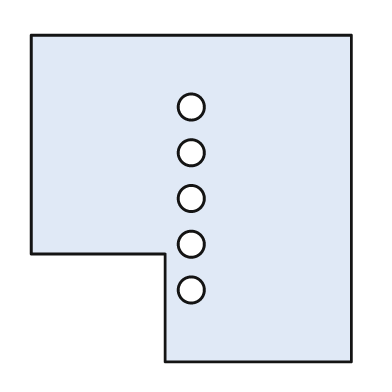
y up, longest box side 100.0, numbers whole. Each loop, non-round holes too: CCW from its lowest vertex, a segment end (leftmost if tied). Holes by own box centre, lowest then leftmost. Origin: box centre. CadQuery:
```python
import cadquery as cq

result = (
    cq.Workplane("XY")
    .moveTo(-8.0, -50.0)
    .lineTo(49.0, -50.0)
    .lineTo(49.0, 50.0)
    .lineTo(-49.0, 50.0)
    .lineTo(-49.0, -17.0)
    .lineTo(-8.0, -17.0)
    .close()
    .moveTo(0.0, -28.0)
    .circle(4.0)
    .moveTo(0.0, -14.0)
    .circle(4.0)
    .moveTo(0.0, 0.0)
    .circle(4.0)
    .moveTo(0.0, 14.0)
    .circle(4.0)
    .moveTo(0.0, 28.0)
    .circle(4.0)
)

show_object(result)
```